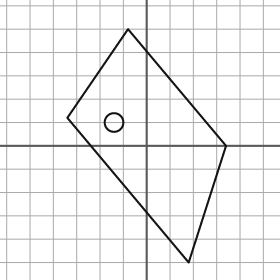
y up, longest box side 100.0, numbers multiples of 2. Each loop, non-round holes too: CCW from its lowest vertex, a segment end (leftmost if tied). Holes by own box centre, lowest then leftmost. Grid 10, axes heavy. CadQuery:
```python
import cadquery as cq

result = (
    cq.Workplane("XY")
    .moveTo(18.0, -50.0)
    .lineTo(34.0, 0.0)
    .lineTo(-8.0, 50.0)
    .lineTo(-34.0, 12.0)
    .close()
    .moveTo(-14.0, 10.0)
    .circle(4.0)
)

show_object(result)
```